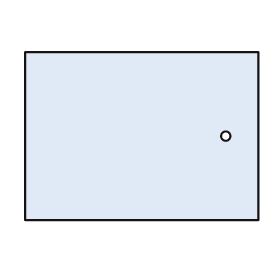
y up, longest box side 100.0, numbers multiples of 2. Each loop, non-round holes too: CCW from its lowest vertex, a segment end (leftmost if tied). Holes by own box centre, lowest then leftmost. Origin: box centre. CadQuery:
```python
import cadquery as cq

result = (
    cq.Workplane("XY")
    .moveTo(-50.0, -36.0)
    .lineTo(50.0, -36.0)
    .lineTo(50.0, 36.0)
    .lineTo(-50.0, 36.0)
    .close()
    .moveTo(36.0, 0.0)
    .circle(2.0)
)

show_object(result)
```